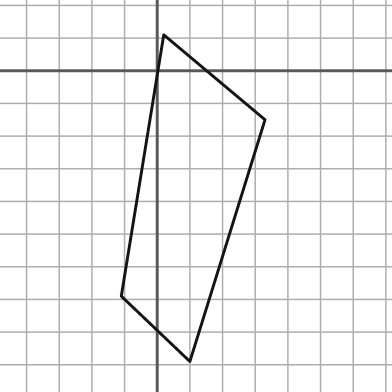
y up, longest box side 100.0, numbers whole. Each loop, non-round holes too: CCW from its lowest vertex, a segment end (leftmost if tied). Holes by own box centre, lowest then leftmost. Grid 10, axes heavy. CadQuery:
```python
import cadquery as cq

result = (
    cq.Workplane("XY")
    .moveTo(10.0, -89.0)
    .lineTo(33.0, -15.0)
    .lineTo(2.0, 11.0)
    .lineTo(-11.0, -69.0)
    .close()
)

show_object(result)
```